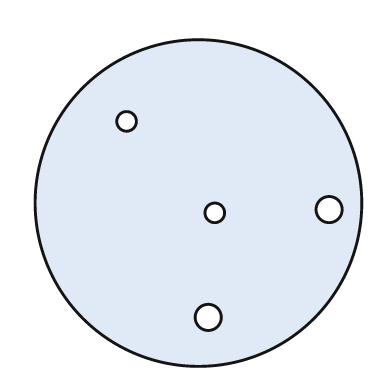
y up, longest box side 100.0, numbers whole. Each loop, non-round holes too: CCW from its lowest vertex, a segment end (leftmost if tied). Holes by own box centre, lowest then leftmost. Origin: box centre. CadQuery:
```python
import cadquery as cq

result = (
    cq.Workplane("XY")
    .moveTo(0.0, 0.0)
    .circle(50.0)
    .moveTo(3.0, -35.0)
    .circle(4.0)
    .moveTo(5.0, -3.0)
    .circle(3.0)
    .moveTo(40.0, -2.0)
    .circle(4.0)
    .moveTo(-22.0, 25.0)
    .circle(3.0)
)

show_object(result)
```